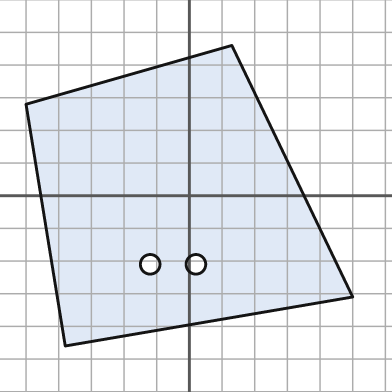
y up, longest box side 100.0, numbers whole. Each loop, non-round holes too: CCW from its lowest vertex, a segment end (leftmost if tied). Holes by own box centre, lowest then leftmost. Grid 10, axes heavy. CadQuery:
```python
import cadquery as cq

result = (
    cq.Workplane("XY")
    .moveTo(-38.0, -46.0)
    .lineTo(50.0, -31.0)
    .lineTo(13.0, 46.0)
    .lineTo(-50.0, 28.0)
    .close()
    .moveTo(-12.0, -21.0)
    .circle(3.0)
    .moveTo(2.0, -21.0)
    .circle(3.0)
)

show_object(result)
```